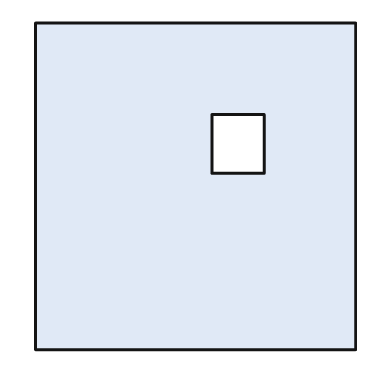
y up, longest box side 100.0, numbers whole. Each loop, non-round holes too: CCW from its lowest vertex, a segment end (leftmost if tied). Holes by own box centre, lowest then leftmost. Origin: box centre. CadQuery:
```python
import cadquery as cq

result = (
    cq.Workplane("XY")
    .moveTo(-49.0, -50.0)
    .lineTo(49.0, -50.0)
    .lineTo(49.0, 50.0)
    .lineTo(-49.0, 50.0)
    .close()
    .moveTo(5.0, 4.0)
    .lineTo(21.0, 4.0)
    .lineTo(21.0, 22.0)
    .lineTo(5.0, 22.0)
    .close()
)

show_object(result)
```